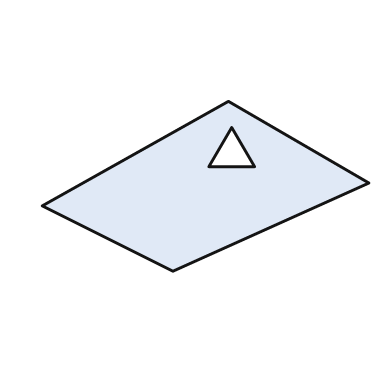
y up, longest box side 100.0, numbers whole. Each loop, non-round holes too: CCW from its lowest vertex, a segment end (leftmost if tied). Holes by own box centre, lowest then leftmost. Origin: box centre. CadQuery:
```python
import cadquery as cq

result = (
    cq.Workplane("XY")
    .moveTo(-10.0, -26.0)
    .lineTo(50.0, 1.0)
    .lineTo(7.0, 26.0)
    .lineTo(-50.0, -6.0)
    .close()
    .moveTo(1.0, 6.0)
    .lineTo(15.0, 6.0)
    .lineTo(8.0, 18.0)
    .close()
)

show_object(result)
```